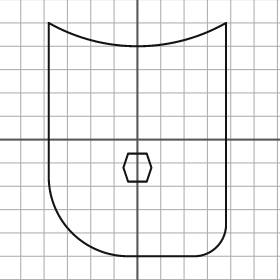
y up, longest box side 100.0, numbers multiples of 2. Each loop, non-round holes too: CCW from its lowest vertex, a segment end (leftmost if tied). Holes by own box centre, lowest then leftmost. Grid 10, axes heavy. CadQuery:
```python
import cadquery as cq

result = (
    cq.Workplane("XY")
    .moveTo(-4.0, -50.0)
    .lineTo(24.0, -50.0)
    .threePointArc((34.0, -46.0), (38.0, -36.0))
    .lineTo(38.0, 50.0)
    .threePointArc((0.0, 40.0), (-38.0, 50.0))
    .lineTo(-38.0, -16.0)
    .threePointArc((-28.0, -40.0), (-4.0, -50.0))
    .close()
    .moveTo(-4.0, -18.0)
    .lineTo(4.0, -18.0)
    .lineTo(6.0, -12.0)
    .lineTo(4.0, -6.0)
    .lineTo(-4.0, -6.0)
    .lineTo(-6.0, -12.0)
    .close()
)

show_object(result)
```